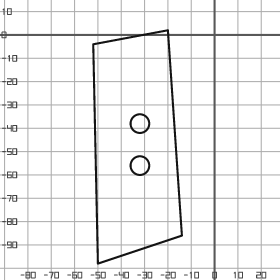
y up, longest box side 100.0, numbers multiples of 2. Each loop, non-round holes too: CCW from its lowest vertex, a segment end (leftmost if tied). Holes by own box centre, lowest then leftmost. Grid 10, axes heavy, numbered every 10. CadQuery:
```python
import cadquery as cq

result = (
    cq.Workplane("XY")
    .moveTo(-50.0, -98.0)
    .lineTo(-14.0, -86.0)
    .lineTo(-20.0, 2.0)
    .lineTo(-52.0, -4.0)
    .close()
    .moveTo(-32.0, -56.0)
    .circle(4.0)
    .moveTo(-32.0, -38.0)
    .circle(4.0)
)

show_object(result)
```